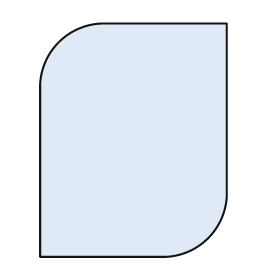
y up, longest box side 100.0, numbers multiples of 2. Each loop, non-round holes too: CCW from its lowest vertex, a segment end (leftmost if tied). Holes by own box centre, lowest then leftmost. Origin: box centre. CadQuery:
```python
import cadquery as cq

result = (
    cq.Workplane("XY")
    .moveTo(-40.0, -50.0)
    .lineTo(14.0, -50.0)
    .threePointArc((32.0, -42.0), (40.0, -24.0))
    .lineTo(40.0, 50.0)
    .lineTo(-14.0, 50.0)
    .threePointArc((-32.0, 42.0), (-40.0, 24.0))
    .close()
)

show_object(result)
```